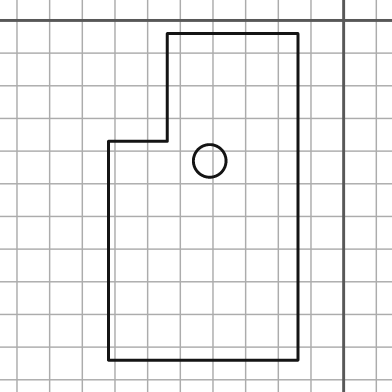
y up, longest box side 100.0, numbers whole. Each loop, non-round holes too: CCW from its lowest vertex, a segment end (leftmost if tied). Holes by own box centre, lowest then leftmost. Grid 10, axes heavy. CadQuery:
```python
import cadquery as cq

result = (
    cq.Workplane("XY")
    .moveTo(-72.0, -104.0)
    .lineTo(-14.0, -104.0)
    .lineTo(-14.0, -4.0)
    .lineTo(-54.0, -4.0)
    .lineTo(-54.0, -37.0)
    .lineTo(-72.0, -37.0)
    .close()
    .moveTo(-41.0, -43.0)
    .circle(5.0)
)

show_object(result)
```